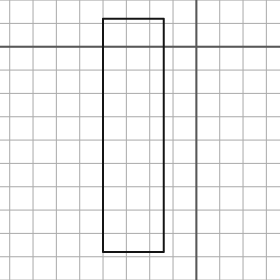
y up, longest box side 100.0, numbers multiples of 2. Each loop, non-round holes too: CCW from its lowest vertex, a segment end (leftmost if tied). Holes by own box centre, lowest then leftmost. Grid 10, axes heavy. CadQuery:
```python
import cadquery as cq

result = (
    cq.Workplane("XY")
    .moveTo(-40.0, -88.0)
    .lineTo(-14.0, -88.0)
    .lineTo(-14.0, 12.0)
    .lineTo(-40.0, 12.0)
    .close()
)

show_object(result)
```